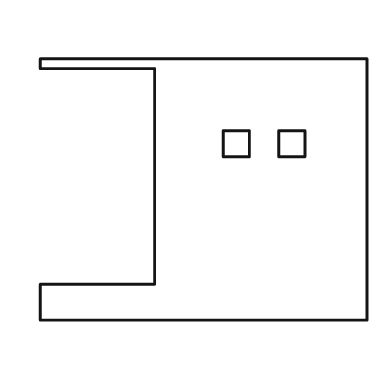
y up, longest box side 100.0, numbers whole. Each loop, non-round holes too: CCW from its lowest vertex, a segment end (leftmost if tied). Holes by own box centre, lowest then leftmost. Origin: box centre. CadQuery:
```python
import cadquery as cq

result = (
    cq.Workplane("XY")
    .moveTo(-50.0, -40.0)
    .lineTo(50.0, -40.0)
    .lineTo(50.0, 40.0)
    .lineTo(-50.0, 40.0)
    .lineTo(-50.0, 37.0)
    .lineTo(-15.0, 37.0)
    .lineTo(-15.0, -29.0)
    .lineTo(-50.0, -29.0)
    .close()
    .moveTo(6.0, 10.0)
    .lineTo(14.0, 10.0)
    .lineTo(14.0, 18.0)
    .lineTo(6.0, 18.0)
    .close()
    .moveTo(23.0, 10.0)
    .lineTo(31.0, 10.0)
    .lineTo(31.0, 18.0)
    .lineTo(23.0, 18.0)
    .close()
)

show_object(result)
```